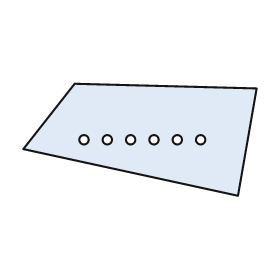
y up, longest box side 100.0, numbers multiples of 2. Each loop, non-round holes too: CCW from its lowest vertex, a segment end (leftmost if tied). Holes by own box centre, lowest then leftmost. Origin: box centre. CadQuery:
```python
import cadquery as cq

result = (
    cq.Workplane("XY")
    .moveTo(42.0, -24.0)
    .lineTo(50.0, 22.0)
    .lineTo(-28.0, 24.0)
    .lineTo(-50.0, -4.0)
    .close()
    .moveTo(-24.0, 0.0)
    .circle(2.0)
    .moveTo(-14.0, 0.0)
    .circle(2.0)
    .moveTo(-4.0, 0.0)
    .circle(2.0)
    .moveTo(6.0, 0.0)
    .circle(2.0)
    .moveTo(16.0, 0.0)
    .circle(2.0)
    .moveTo(26.0, 0.0)
    .circle(2.0)
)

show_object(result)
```